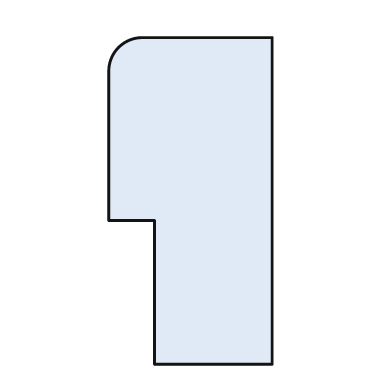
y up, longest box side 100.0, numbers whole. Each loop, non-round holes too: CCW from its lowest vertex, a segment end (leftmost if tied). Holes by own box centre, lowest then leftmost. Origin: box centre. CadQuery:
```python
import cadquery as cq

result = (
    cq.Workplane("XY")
    .moveTo(-11.0, -50.0)
    .lineTo(25.0, -50.0)
    .lineTo(25.0, 50.0)
    .lineTo(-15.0, 50.0)
    .threePointArc((-22.0, 47.0), (-25.0, 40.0))
    .lineTo(-25.0, -6.0)
    .lineTo(-11.0, -6.0)
    .close()
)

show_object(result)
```